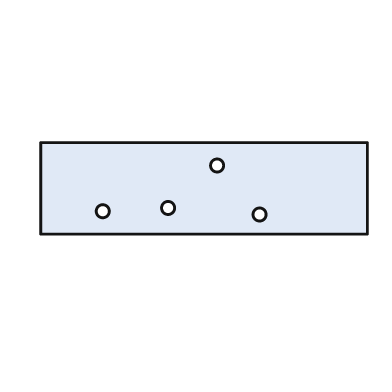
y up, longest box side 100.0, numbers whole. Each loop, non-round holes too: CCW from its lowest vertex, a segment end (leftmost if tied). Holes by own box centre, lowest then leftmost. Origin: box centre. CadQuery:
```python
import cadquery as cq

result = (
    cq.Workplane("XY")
    .moveTo(-50.0, -14.0)
    .lineTo(50.0, -14.0)
    .lineTo(50.0, 14.0)
    .lineTo(-50.0, 14.0)
    .close()
    .moveTo(17.0, -8.0)
    .circle(2.0)
    .moveTo(-31.0, -7.0)
    .circle(2.0)
    .moveTo(-11.0, -6.0)
    .circle(2.0)
    .moveTo(4.0, 7.0)
    .circle(2.0)
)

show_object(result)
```